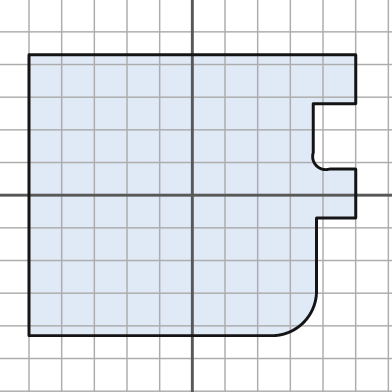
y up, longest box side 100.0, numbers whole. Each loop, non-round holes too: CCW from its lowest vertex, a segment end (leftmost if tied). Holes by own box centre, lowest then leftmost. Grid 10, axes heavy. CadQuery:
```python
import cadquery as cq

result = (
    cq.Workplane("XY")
    .moveTo(-50.0, -43.0)
    .lineTo(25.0, -43.0)
    .threePointArc((34.0, -39.0), (38.0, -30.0))
    .lineTo(38.0, -7.0)
    .lineTo(50.0, -7.0)
    .lineTo(50.0, 8.0)
    .lineTo(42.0, 8.0)
    .threePointArc((38.0, 9.0), (37.0, 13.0))
    .lineTo(37.0, 28.0)
    .lineTo(50.0, 28.0)
    .lineTo(50.0, 43.0)
    .lineTo(-50.0, 43.0)
    .close()
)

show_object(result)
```